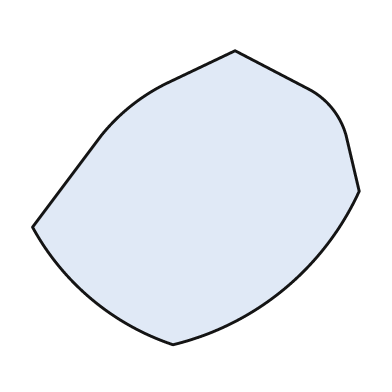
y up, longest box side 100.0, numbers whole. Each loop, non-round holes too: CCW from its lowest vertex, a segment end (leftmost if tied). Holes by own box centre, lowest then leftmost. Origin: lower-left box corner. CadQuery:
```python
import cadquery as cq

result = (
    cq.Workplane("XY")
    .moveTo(43.0, 0.0)
    .threePointArc((77.0, 17.0), (100.0, 47.0))
    .lineTo(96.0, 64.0)
    .threePointArc((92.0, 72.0), (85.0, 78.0))
    .lineTo(62.0, 90.0)
    .lineTo(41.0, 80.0)
    .threePointArc((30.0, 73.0), (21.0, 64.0))
    .lineTo(0.0, 36.0)
    .threePointArc((18.0, 14.0), (43.0, 0.0))
    .close()
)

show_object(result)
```